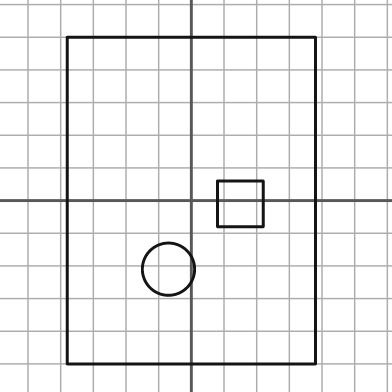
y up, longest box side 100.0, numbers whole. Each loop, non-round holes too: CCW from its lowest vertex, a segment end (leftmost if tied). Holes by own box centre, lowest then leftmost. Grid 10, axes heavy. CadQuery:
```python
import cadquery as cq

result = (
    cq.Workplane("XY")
    .moveTo(-38.0, -50.0)
    .lineTo(38.0, -50.0)
    .lineTo(38.0, 50.0)
    .lineTo(-38.0, 50.0)
    .close()
    .moveTo(-7.0, -21.0)
    .circle(8.0)
    .moveTo(8.0, -8.0)
    .lineTo(22.0, -8.0)
    .lineTo(22.0, 6.0)
    .lineTo(8.0, 6.0)
    .close()
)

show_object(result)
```